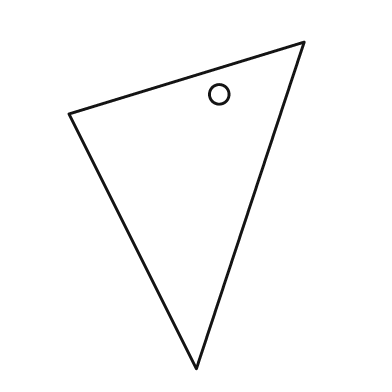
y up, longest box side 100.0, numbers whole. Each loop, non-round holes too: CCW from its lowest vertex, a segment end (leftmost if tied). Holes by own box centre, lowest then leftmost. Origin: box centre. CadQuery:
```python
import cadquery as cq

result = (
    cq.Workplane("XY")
    .moveTo(3.0, -50.0)
    .lineTo(36.0, 50.0)
    .lineTo(-36.0, 28.0)
    .close()
    .moveTo(10.0, 34.0)
    .circle(3.0)
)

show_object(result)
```